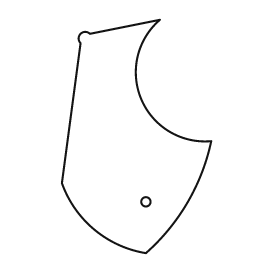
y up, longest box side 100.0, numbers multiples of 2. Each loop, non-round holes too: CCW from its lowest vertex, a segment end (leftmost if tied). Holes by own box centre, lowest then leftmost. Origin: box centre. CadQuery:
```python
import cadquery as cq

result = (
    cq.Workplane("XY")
    .moveTo(4.0, -50.0)
    .threePointArc((22.0, -28.0), (32.0, -2.0))
    .threePointArc((2.0, 16.0), (10.0, 50.0))
    .lineTo(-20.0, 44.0)
    .threePointArc((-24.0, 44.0), (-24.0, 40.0))
    .lineTo(-32.0, -20.0)
    .threePointArc((-18.0, -40.0), (4.0, -50.0))
    .close()
    .moveTo(4.0, -28.0)
    .circle(2.0)
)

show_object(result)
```